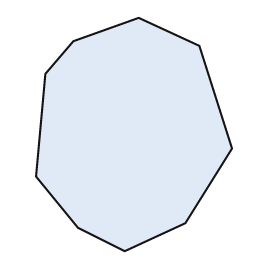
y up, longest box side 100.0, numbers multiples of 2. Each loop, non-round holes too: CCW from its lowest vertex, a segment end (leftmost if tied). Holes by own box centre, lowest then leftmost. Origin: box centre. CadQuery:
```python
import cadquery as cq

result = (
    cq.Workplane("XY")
    .moveTo(-4.0, -50.0)
    .lineTo(22.0, -38.0)
    .lineTo(42.0, -6.0)
    .lineTo(28.0, 38.0)
    .lineTo(2.0, 50.0)
    .lineTo(-26.0, 40.0)
    .lineTo(-38.0, 26.0)
    .lineTo(-42.0, -18.0)
    .lineTo(-24.0, -40.0)
    .close()
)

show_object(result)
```